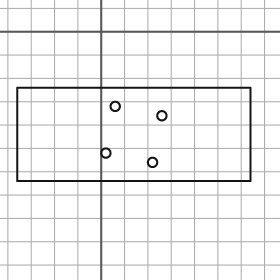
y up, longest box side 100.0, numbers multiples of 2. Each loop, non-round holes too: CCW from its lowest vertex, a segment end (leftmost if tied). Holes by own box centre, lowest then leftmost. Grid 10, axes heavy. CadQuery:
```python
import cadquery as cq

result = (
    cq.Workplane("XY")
    .moveTo(-36.0, -64.0)
    .lineTo(64.0, -64.0)
    .lineTo(64.0, -24.0)
    .lineTo(-36.0, -24.0)
    .close()
    .moveTo(22.0, -56.0)
    .circle(2.0)
    .moveTo(2.0, -52.0)
    .circle(2.0)
    .moveTo(26.0, -36.0)
    .circle(2.0)
    .moveTo(6.0, -32.0)
    .circle(2.0)
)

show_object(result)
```